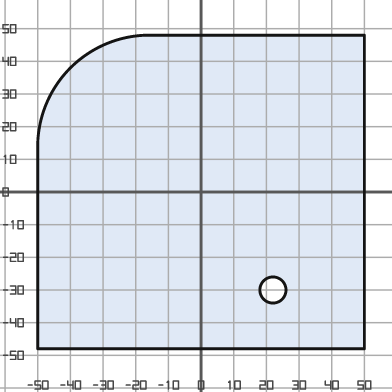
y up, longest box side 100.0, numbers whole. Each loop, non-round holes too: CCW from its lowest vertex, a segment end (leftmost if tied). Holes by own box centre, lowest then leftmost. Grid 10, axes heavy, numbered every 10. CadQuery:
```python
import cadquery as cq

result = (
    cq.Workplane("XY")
    .moveTo(-50.0, -48.0)
    .lineTo(50.0, -48.0)
    .lineTo(50.0, 48.0)
    .lineTo(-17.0, 48.0)
    .threePointArc((-40.0, 38.0), (-50.0, 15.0))
    .close()
    .moveTo(22.0, -30.0)
    .circle(4.0)
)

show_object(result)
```